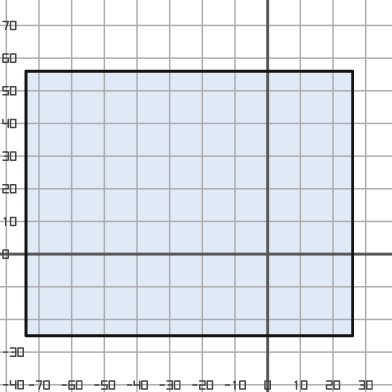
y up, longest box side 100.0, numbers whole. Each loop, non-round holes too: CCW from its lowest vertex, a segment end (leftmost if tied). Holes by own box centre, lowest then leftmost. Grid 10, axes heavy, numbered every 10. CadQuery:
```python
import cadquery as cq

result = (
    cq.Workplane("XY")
    .moveTo(-74.0, -25.0)
    .lineTo(26.0, -25.0)
    .lineTo(26.0, 56.0)
    .lineTo(-74.0, 56.0)
    .close()
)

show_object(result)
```